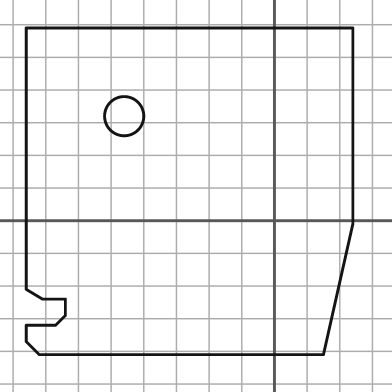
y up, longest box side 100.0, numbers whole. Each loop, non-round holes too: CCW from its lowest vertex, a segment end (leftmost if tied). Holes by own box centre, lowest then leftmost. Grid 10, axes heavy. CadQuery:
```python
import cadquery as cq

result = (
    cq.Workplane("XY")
    .moveTo(-72.0, -41.0)
    .lineTo(15.0, -41.0)
    .lineTo(24.0, -1.0)
    .lineTo(24.0, 59.0)
    .lineTo(-76.0, 59.0)
    .lineTo(-76.0, -21.0)
    .lineTo(-71.0, -24.0)
    .lineTo(-64.0, -24.0)
    .lineTo(-64.0, -29.0)
    .lineTo(-67.0, -32.0)
    .lineTo(-76.0, -32.0)
    .lineTo(-76.0, -37.0)
    .close()
    .moveTo(-46.0, 32.0)
    .circle(6.0)
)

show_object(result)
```